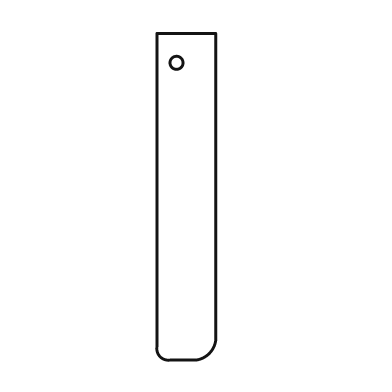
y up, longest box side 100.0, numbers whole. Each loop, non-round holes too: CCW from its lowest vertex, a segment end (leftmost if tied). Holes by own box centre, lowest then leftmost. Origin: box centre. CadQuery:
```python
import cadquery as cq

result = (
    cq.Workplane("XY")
    .moveTo(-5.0, -50.0)
    .lineTo(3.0, -50.0)
    .threePointArc((7.0, -48.0), (9.0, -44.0))
    .lineTo(9.0, 50.0)
    .lineTo(-9.0, 50.0)
    .lineTo(-9.0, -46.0)
    .threePointArc((-8.0, -49.0), (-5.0, -50.0))
    .close()
    .moveTo(-3.0, 41.0)
    .circle(2.0)
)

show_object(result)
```